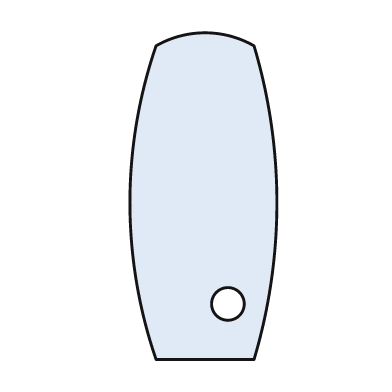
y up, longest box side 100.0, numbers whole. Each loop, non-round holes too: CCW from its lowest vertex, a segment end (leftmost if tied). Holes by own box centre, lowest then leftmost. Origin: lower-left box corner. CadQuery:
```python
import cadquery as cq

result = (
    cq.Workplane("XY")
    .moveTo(8.0, 0.0)
    .lineTo(38.0, 0.0)
    .threePointArc((45.0, 48.0), (38.0, 96.0))
    .threePointArc((23.0, 100.0), (8.0, 96.0))
    .threePointArc((0.0, 48.0), (8.0, 0.0))
    .close()
    .moveTo(30.0, 17.0)
    .circle(5.0)
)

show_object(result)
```